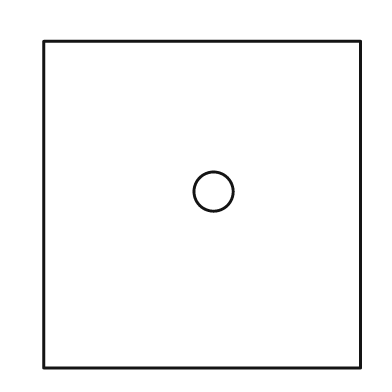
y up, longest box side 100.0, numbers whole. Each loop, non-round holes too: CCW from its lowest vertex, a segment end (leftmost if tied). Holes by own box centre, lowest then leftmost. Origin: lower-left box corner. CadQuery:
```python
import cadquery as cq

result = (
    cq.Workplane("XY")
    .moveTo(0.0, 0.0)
    .lineTo(97.0, 0.0)
    .lineTo(97.0, 100.0)
    .lineTo(0.0, 100.0)
    .close()
    .moveTo(52.0, 54.0)
    .circle(6.0)
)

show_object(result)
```